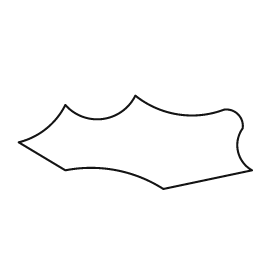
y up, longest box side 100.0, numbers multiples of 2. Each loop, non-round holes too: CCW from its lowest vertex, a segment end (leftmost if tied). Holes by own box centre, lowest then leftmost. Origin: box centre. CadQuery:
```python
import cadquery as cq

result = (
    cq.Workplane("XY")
    .moveTo(12.0, -20.0)
    .lineTo(50.0, -12.0)
    .threePointArc((44.0, -4.0), (46.0, 6.0))
    .threePointArc((44.0, 12.0), (38.0, 14.0))
    .threePointArc((18.0, 12.0), (0.0, 20.0))
    .threePointArc((-14.0, 10.0), (-30.0, 16.0))
    .threePointArc((-38.0, 6.0), (-50.0, 0.0))
    .lineTo(-30.0, -12.0)
    .threePointArc((-8.0, -12.0), (12.0, -20.0))
    .close()
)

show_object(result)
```